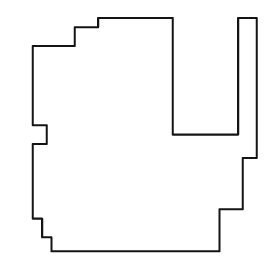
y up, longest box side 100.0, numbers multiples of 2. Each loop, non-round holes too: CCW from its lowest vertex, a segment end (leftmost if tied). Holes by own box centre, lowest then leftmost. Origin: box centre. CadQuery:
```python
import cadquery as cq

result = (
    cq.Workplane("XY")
    .moveTo(-40.0, -50.0)
    .lineTo(32.0, -50.0)
    .lineTo(32.0, -32.0)
    .lineTo(42.0, -32.0)
    .lineTo(42.0, -10.0)
    .lineTo(48.0, -10.0)
    .lineTo(48.0, 50.0)
    .lineTo(40.0, 50.0)
    .lineTo(40.0, 0.0)
    .lineTo(12.0, 0.0)
    .lineTo(12.0, 50.0)
    .lineTo(-20.0, 50.0)
    .lineTo(-20.0, 46.0)
    .lineTo(-30.0, 46.0)
    .lineTo(-30.0, 38.0)
    .lineTo(-48.0, 38.0)
    .lineTo(-48.0, 4.0)
    .lineTo(-42.0, 4.0)
    .lineTo(-42.0, -4.0)
    .lineTo(-48.0, -4.0)
    .lineTo(-48.0, -36.0)
    .lineTo(-44.0, -36.0)
    .lineTo(-44.0, -44.0)
    .lineTo(-40.0, -44.0)
    .close()
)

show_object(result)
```